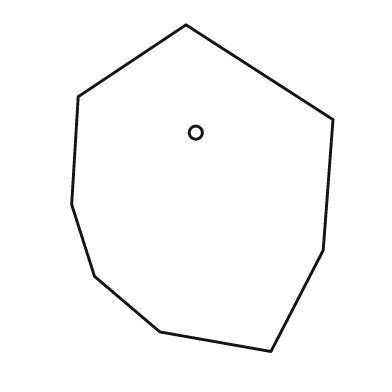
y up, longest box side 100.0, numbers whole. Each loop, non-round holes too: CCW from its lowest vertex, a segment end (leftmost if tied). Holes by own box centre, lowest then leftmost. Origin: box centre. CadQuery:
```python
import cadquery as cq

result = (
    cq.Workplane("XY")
    .moveTo(21.0, -50.0)
    .lineTo(37.0, -19.0)
    .lineTo(40.0, 21.0)
    .lineTo(-5.0, 50.0)
    .lineTo(-38.0, 28.0)
    .lineTo(-40.0, -5.0)
    .lineTo(-33.0, -27.0)
    .lineTo(-13.0, -44.0)
    .close()
    .moveTo(-2.0, 17.0)
    .circle(2.0)
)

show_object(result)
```